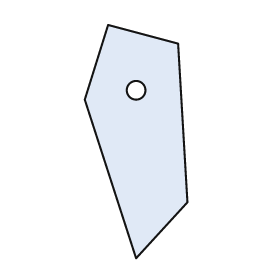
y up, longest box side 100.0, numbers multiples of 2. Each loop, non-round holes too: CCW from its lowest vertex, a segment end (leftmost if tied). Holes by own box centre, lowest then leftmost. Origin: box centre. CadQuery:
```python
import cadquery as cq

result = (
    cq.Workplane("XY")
    .moveTo(0.0, -50.0)
    .lineTo(22.0, -26.0)
    .lineTo(18.0, 42.0)
    .lineTo(-12.0, 50.0)
    .lineTo(-22.0, 18.0)
    .close()
    .moveTo(0.0, 22.0)
    .circle(4.0)
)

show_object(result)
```